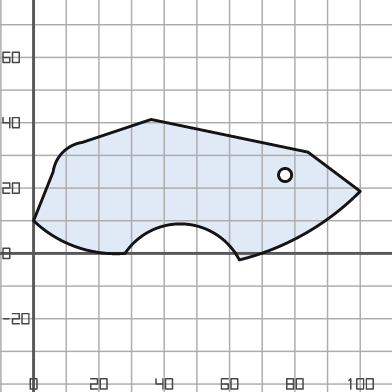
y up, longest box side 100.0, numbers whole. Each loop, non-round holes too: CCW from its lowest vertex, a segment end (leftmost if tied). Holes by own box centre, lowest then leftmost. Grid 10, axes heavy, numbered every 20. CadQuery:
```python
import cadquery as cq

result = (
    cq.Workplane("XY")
    .moveTo(63.0, -2.0)
    .threePointArc((83.0, 6.0), (100.0, 19.0))
    .lineTo(84.0, 31.0)
    .lineTo(36.0, 41.0)
    .lineTo(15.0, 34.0)
    .threePointArc((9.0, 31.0), (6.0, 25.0))
    .lineTo(0.0, 10.0)
    .threePointArc((13.0, 2.0), (28.0, 0.0))
    .threePointArc((46.0, 9.0), (63.0, -2.0))
    .close()
    .moveTo(77.0, 24.0)
    .circle(2.0)
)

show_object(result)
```